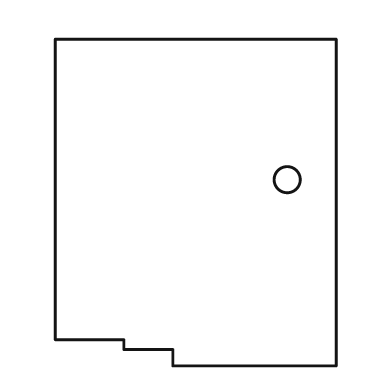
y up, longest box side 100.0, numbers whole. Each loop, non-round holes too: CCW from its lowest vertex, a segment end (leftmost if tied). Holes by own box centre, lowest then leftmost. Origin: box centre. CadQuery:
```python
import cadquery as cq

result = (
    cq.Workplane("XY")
    .moveTo(-7.0, -50.0)
    .lineTo(43.0, -50.0)
    .lineTo(43.0, 50.0)
    .lineTo(-43.0, 50.0)
    .lineTo(-43.0, -42.0)
    .lineTo(-22.0, -42.0)
    .lineTo(-22.0, -45.0)
    .lineTo(-7.0, -45.0)
    .close()
    .moveTo(28.0, 7.0)
    .circle(4.0)
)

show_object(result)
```